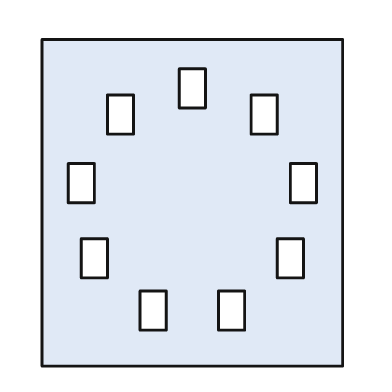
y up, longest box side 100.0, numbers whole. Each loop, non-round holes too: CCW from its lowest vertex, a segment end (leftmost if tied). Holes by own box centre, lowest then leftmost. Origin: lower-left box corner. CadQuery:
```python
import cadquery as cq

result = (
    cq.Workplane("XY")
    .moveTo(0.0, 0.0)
    .lineTo(92.0, 0.0)
    .lineTo(92.0, 100.0)
    .lineTo(0.0, 100.0)
    .close()
    .moveTo(30.0, 11.0)
    .lineTo(38.0, 11.0)
    .lineTo(38.0, 23.0)
    .lineTo(30.0, 23.0)
    .close()
    .moveTo(54.0, 11.0)
    .lineTo(62.0, 11.0)
    .lineTo(62.0, 23.0)
    .lineTo(54.0, 23.0)
    .close()
    .moveTo(12.0, 27.0)
    .lineTo(20.0, 27.0)
    .lineTo(20.0, 39.0)
    .lineTo(12.0, 39.0)
    .close()
    .moveTo(72.0, 27.0)
    .lineTo(80.0, 27.0)
    .lineTo(80.0, 39.0)
    .lineTo(72.0, 39.0)
    .close()
    .moveTo(8.0, 50.0)
    .lineTo(16.0, 50.0)
    .lineTo(16.0, 62.0)
    .lineTo(8.0, 62.0)
    .close()
    .moveTo(76.0, 50.0)
    .lineTo(84.0, 50.0)
    .lineTo(84.0, 62.0)
    .lineTo(76.0, 62.0)
    .close()
    .moveTo(20.0, 71.0)
    .lineTo(28.0, 71.0)
    .lineTo(28.0, 83.0)
    .lineTo(20.0, 83.0)
    .close()
    .moveTo(64.0, 71.0)
    .lineTo(72.0, 71.0)
    .lineTo(72.0, 83.0)
    .lineTo(64.0, 83.0)
    .close()
    .moveTo(42.0, 79.0)
    .lineTo(50.0, 79.0)
    .lineTo(50.0, 91.0)
    .lineTo(42.0, 91.0)
    .close()
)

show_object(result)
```